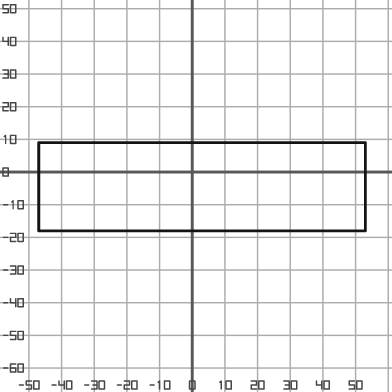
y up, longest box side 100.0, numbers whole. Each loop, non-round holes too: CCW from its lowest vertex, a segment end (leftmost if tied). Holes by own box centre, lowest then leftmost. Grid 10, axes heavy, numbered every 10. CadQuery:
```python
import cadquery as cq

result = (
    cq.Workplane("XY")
    .moveTo(-47.0, -18.0)
    .lineTo(53.0, -18.0)
    .lineTo(53.0, 9.0)
    .lineTo(-47.0, 9.0)
    .close()
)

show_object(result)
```